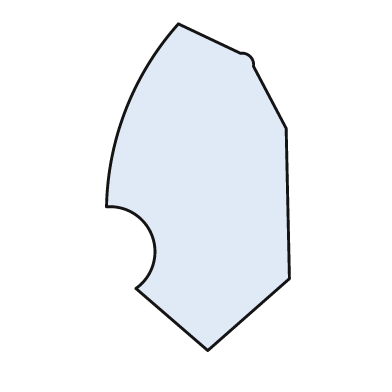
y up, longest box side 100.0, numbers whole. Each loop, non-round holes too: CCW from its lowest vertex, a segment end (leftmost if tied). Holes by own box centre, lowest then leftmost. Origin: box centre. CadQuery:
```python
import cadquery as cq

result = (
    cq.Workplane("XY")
    .moveTo(3.0, -50.0)
    .lineTo(28.0, -28.0)
    .lineTo(27.0, 18.0)
    .lineTo(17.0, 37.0)
    .threePointArc((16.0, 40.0), (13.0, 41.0))
    .lineTo(-6.0, 50.0)
    .threePointArc((-22.0, 24.0), (-28.0, -6.0))
    .threePointArc((-14.0, -15.0), (-19.0, -31.0))
    .close()
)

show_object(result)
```